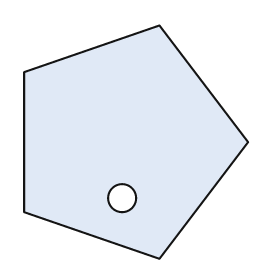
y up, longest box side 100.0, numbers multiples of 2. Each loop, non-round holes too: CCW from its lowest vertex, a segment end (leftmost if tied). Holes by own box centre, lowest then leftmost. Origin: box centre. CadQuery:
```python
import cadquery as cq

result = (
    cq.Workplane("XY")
    .moveTo(10.0, -50.0)
    .lineTo(48.0, 0.0)
    .lineTo(10.0, 50.0)
    .lineTo(-48.0, 30.0)
    .lineTo(-48.0, -30.0)
    .close()
    .moveTo(-6.0, -24.0)
    .circle(6.0)
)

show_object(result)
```